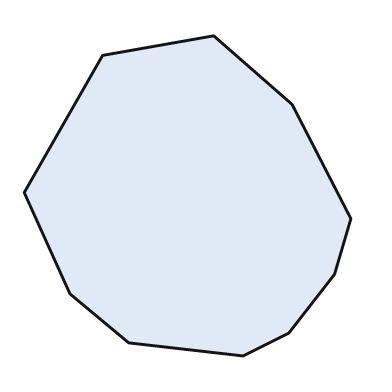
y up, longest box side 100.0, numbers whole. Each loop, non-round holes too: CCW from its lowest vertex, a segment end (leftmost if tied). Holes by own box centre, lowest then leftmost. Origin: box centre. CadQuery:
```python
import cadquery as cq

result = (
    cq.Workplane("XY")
    .moveTo(17.0, -49.0)
    .lineTo(31.0, -42.0)
    .lineTo(45.0, -24.0)
    .lineTo(50.0, -7.0)
    .lineTo(32.0, 28.0)
    .lineTo(8.0, 49.0)
    .lineTo(-26.0, 43.0)
    .lineTo(-50.0, 1.0)
    .lineTo(-36.0, -30.0)
    .lineTo(-18.0, -45.0)
    .close()
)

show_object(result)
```